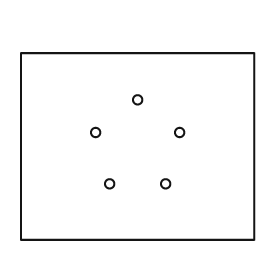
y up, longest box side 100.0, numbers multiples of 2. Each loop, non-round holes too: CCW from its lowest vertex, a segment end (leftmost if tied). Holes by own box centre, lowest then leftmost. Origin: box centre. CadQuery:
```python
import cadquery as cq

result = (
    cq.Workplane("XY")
    .moveTo(-50.0, -40.0)
    .lineTo(50.0, -40.0)
    .lineTo(50.0, 40.0)
    .lineTo(-50.0, 40.0)
    .close()
    .moveTo(-12.0, -16.0)
    .circle(2.0)
    .moveTo(12.0, -16.0)
    .circle(2.0)
    .moveTo(-18.0, 6.0)
    .circle(2.0)
    .moveTo(18.0, 6.0)
    .circle(2.0)
    .moveTo(0.0, 20.0)
    .circle(2.0)
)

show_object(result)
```